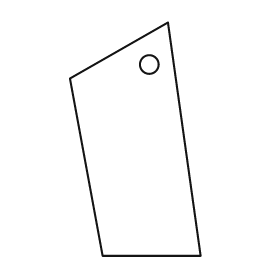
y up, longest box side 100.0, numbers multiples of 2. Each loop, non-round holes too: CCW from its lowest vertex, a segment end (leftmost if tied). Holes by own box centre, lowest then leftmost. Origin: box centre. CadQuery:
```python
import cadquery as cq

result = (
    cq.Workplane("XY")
    .moveTo(-14.0, -50.0)
    .lineTo(28.0, -50.0)
    .lineTo(14.0, 50.0)
    .lineTo(-28.0, 26.0)
    .close()
    .moveTo(6.0, 32.0)
    .circle(4.0)
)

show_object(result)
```